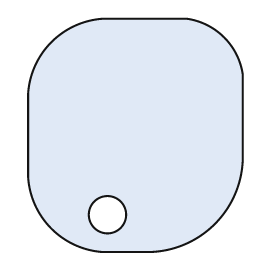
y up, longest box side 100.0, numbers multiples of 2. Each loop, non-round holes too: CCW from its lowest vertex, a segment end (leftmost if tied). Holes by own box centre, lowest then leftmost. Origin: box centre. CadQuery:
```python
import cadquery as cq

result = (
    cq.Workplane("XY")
    .moveTo(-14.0, -50.0)
    .lineTo(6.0, -50.0)
    .threePointArc((34.0, -38.0), (46.0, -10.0))
    .lineTo(46.0, 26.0)
    .threePointArc((38.0, 42.0), (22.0, 50.0))
    .lineTo(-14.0, 50.0)
    .threePointArc((-36.0, 40.0), (-46.0, 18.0))
    .lineTo(-46.0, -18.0)
    .threePointArc((-36.0, -40.0), (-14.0, -50.0))
    .close()
    .moveTo(-12.0, -34.0)
    .circle(8.0)
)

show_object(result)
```